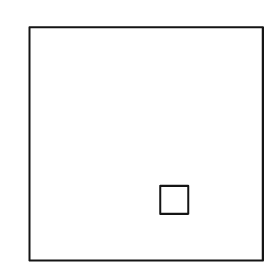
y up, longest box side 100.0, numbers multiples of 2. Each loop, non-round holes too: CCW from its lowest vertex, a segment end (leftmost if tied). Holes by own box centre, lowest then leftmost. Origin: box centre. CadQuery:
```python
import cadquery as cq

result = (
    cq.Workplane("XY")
    .moveTo(-50.0, -50.0)
    .lineTo(50.0, -50.0)
    .lineTo(50.0, 50.0)
    .lineTo(-50.0, 50.0)
    .close()
    .moveTo(6.0, -30.0)
    .lineTo(18.0, -30.0)
    .lineTo(18.0, -18.0)
    .lineTo(6.0, -18.0)
    .close()
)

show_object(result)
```